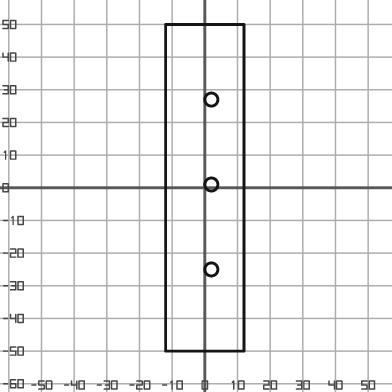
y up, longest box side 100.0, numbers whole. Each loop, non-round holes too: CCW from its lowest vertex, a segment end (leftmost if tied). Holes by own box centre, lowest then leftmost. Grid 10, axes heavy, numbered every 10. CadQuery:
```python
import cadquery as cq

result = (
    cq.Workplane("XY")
    .moveTo(-12.0, -50.0)
    .lineTo(12.0, -50.0)
    .lineTo(12.0, 50.0)
    .lineTo(-12.0, 50.0)
    .close()
    .moveTo(2.0, -25.0)
    .circle(2.0)
    .moveTo(2.0, 1.0)
    .circle(2.0)
    .moveTo(2.0, 27.0)
    .circle(2.0)
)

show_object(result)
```